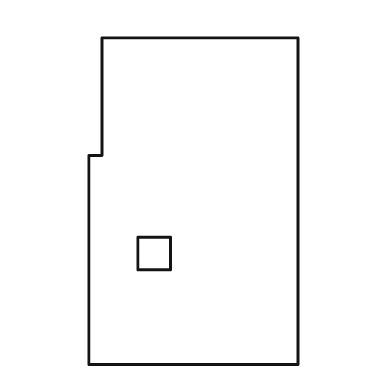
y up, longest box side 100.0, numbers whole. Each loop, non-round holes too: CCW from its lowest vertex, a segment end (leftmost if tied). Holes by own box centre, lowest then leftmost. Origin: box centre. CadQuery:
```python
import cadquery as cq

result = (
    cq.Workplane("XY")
    .moveTo(-32.0, -50.0)
    .lineTo(32.0, -50.0)
    .lineTo(32.0, 50.0)
    .lineTo(-28.0, 50.0)
    .lineTo(-28.0, 14.0)
    .lineTo(-32.0, 14.0)
    .close()
    .moveTo(-17.0, -21.0)
    .lineTo(-7.0, -21.0)
    .lineTo(-7.0, -11.0)
    .lineTo(-17.0, -11.0)
    .close()
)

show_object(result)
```